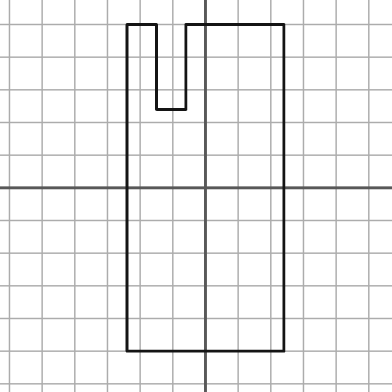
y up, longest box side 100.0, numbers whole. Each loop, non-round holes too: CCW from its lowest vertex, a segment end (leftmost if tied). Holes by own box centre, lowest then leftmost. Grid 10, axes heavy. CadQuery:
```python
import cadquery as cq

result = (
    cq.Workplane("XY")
    .moveTo(-24.0, -50.0)
    .lineTo(24.0, -50.0)
    .lineTo(24.0, 50.0)
    .lineTo(-6.0, 50.0)
    .lineTo(-6.0, 24.0)
    .lineTo(-15.0, 24.0)
    .lineTo(-15.0, 50.0)
    .lineTo(-24.0, 50.0)
    .close()
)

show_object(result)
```